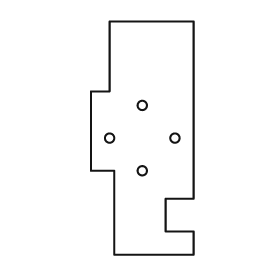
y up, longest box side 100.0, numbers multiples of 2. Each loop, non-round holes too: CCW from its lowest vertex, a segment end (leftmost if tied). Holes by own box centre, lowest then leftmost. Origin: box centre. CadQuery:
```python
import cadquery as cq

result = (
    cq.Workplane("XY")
    .moveTo(-12.0, -50.0)
    .lineTo(22.0, -50.0)
    .lineTo(22.0, -40.0)
    .lineTo(10.0, -40.0)
    .lineTo(10.0, -26.0)
    .lineTo(22.0, -26.0)
    .lineTo(22.0, 50.0)
    .lineTo(-14.0, 50.0)
    .lineTo(-14.0, 20.0)
    .lineTo(-22.0, 20.0)
    .lineTo(-22.0, -14.0)
    .lineTo(-12.0, -14.0)
    .close()
    .moveTo(0.0, -14.0)
    .circle(2.0)
    .moveTo(-14.0, 0.0)
    .circle(2.0)
    .moveTo(14.0, 0.0)
    .circle(2.0)
    .moveTo(0.0, 14.0)
    .circle(2.0)
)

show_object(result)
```